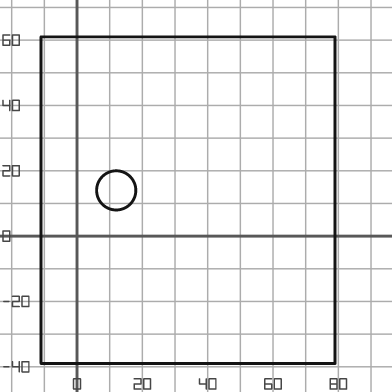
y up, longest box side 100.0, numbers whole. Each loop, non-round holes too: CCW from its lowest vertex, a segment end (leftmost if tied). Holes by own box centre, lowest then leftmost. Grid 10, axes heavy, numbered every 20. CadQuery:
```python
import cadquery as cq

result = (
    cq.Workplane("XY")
    .moveTo(-11.0, -39.0)
    .lineTo(79.0, -39.0)
    .lineTo(79.0, 61.0)
    .lineTo(-11.0, 61.0)
    .close()
    .moveTo(12.0, 14.0)
    .circle(6.0)
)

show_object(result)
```